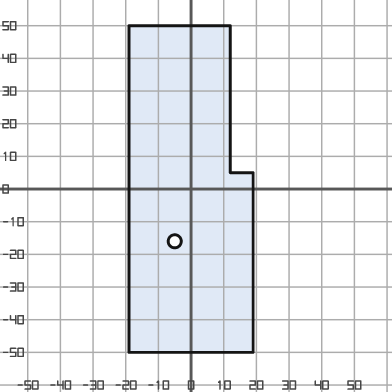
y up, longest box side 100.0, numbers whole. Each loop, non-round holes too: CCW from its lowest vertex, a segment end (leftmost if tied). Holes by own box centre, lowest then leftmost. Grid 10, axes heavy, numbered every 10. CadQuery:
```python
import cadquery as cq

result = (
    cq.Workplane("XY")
    .moveTo(-19.0, -50.0)
    .lineTo(19.0, -50.0)
    .lineTo(19.0, 5.0)
    .lineTo(12.0, 5.0)
    .lineTo(12.0, 50.0)
    .lineTo(-19.0, 50.0)
    .close()
    .moveTo(-5.0, -16.0)
    .circle(2.0)
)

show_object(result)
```